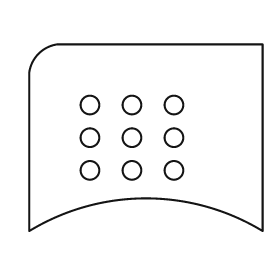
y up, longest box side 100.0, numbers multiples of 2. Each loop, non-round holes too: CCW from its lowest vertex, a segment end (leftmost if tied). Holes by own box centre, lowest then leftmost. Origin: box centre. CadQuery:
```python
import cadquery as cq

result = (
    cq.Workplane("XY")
    .moveTo(-50.0, -40.0)
    .threePointArc((0.0, -26.0), (50.0, -40.0))
    .lineTo(50.0, 40.0)
    .lineTo(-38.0, 40.0)
    .threePointArc((-46.0, 36.0), (-50.0, 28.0))
    .close()
    .moveTo(-24.0, -14.0)
    .circle(4.0)
    .moveTo(-6.0, -14.0)
    .circle(4.0)
    .moveTo(12.0, -14.0)
    .circle(4.0)
    .moveTo(-24.0, 0.0)
    .circle(4.0)
    .moveTo(-6.0, 0.0)
    .circle(4.0)
    .moveTo(12.0, 0.0)
    .circle(4.0)
    .moveTo(-24.0, 14.0)
    .circle(4.0)
    .moveTo(-6.0, 14.0)
    .circle(4.0)
    .moveTo(12.0, 14.0)
    .circle(4.0)
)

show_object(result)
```